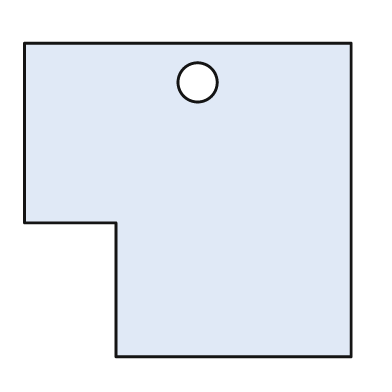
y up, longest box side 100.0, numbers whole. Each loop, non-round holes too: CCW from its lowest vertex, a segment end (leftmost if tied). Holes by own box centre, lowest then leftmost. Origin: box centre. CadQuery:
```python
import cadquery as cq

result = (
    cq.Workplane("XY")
    .moveTo(-22.0, -48.0)
    .lineTo(50.0, -48.0)
    .lineTo(50.0, 48.0)
    .lineTo(-50.0, 48.0)
    .lineTo(-50.0, -7.0)
    .lineTo(-22.0, -7.0)
    .close()
    .moveTo(3.0, 36.0)
    .circle(6.0)
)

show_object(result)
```